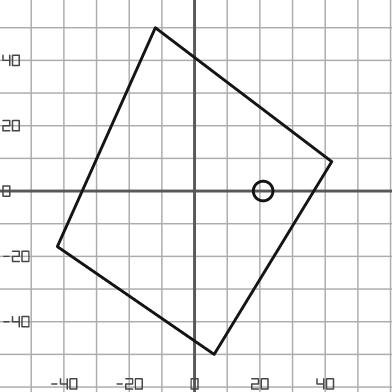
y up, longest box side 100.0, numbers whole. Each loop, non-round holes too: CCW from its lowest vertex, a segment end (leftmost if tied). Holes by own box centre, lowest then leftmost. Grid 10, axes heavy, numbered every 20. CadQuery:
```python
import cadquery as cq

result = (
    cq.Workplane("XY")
    .moveTo(6.0, -50.0)
    .lineTo(42.0, 9.0)
    .lineTo(-12.0, 50.0)
    .lineTo(-42.0, -17.0)
    .close()
    .moveTo(21.0, 0.0)
    .circle(3.0)
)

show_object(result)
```